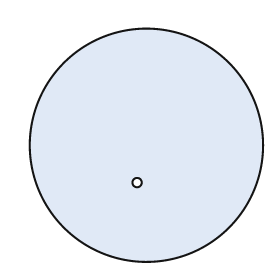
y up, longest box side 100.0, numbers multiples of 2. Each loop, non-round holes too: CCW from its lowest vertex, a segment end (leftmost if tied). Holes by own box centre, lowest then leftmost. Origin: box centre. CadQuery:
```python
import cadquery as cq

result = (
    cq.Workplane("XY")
    .moveTo(0.0, 0.0)
    .circle(50.0)
    .moveTo(-4.0, -16.0)
    .circle(2.0)
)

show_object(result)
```